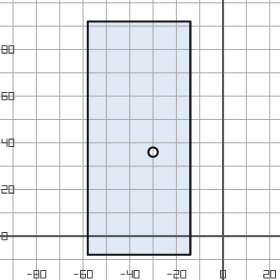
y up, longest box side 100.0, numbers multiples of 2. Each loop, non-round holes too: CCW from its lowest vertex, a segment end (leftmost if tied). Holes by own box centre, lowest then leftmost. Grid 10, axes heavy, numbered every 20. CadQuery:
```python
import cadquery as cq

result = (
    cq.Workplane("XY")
    .moveTo(-58.0, -8.0)
    .lineTo(-14.0, -8.0)
    .lineTo(-14.0, 92.0)
    .lineTo(-58.0, 92.0)
    .close()
    .moveTo(-30.0, 36.0)
    .circle(2.0)
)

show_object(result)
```